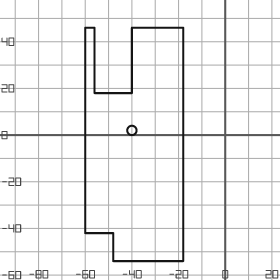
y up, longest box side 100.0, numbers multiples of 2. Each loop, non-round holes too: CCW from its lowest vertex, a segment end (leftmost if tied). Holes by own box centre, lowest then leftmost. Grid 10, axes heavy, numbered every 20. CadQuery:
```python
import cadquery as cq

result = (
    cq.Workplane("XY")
    .moveTo(-48.0, -54.0)
    .lineTo(-18.0, -54.0)
    .lineTo(-18.0, 46.0)
    .lineTo(-40.0, 46.0)
    .lineTo(-40.0, 18.0)
    .lineTo(-56.0, 18.0)
    .lineTo(-56.0, 46.0)
    .lineTo(-60.0, 46.0)
    .lineTo(-60.0, -42.0)
    .lineTo(-48.0, -42.0)
    .close()
    .moveTo(-40.0, 2.0)
    .circle(2.0)
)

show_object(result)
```